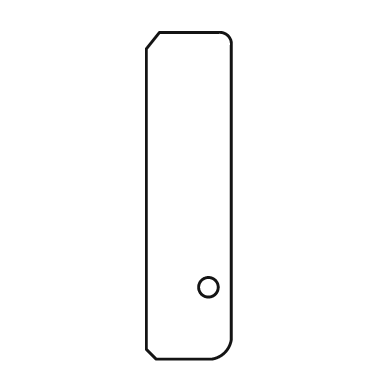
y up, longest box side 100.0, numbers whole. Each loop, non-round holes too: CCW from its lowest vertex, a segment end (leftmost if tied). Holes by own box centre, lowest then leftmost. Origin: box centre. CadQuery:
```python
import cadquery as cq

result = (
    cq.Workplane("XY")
    .moveTo(-10.0, -50.0)
    .lineTo(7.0, -50.0)
    .threePointArc((11.0, -48.0), (13.0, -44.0))
    .lineTo(13.0, 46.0)
    .threePointArc((12.0, 49.0), (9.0, 50.0))
    .lineTo(-9.0, 50.0)
    .lineTo(-13.0, 45.0)
    .lineTo(-13.0, -47.0)
    .close()
    .moveTo(6.0, -28.0)
    .circle(3.0)
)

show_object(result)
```